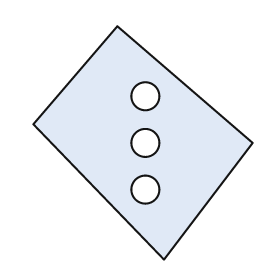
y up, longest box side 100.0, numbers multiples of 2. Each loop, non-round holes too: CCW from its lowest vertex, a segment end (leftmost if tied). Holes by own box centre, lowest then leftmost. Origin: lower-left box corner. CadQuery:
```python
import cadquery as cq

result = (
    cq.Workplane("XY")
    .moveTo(56.0, 0.0)
    .lineTo(94.0, 50.0)
    .lineTo(36.0, 100.0)
    .lineTo(0.0, 58.0)
    .close()
    .moveTo(48.0, 30.0)
    .circle(6.0)
    .moveTo(48.0, 50.0)
    .circle(6.0)
    .moveTo(48.0, 70.0)
    .circle(6.0)
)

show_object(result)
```